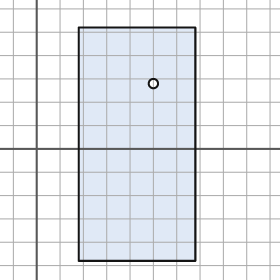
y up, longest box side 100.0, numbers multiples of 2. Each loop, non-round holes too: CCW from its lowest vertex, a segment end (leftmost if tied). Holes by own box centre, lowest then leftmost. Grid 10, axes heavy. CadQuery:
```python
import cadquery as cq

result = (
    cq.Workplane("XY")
    .moveTo(18.0, -48.0)
    .lineTo(68.0, -48.0)
    .lineTo(68.0, 52.0)
    .lineTo(18.0, 52.0)
    .close()
    .moveTo(50.0, 28.0)
    .circle(2.0)
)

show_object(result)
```